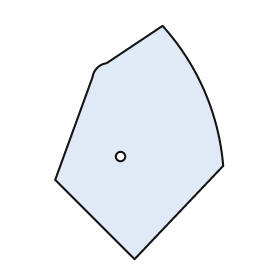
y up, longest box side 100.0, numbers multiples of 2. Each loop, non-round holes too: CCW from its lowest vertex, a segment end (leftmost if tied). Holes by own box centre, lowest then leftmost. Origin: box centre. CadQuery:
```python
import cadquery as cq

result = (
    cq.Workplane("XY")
    .moveTo(-2.0, -50.0)
    .lineTo(36.0, -10.0)
    .threePointArc((28.0, 22.0), (10.0, 50.0))
    .lineTo(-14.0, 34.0)
    .threePointArc((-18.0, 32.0), (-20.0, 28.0))
    .lineTo(-36.0, -16.0)
    .close()
    .moveTo(-8.0, -6.0)
    .circle(2.0)
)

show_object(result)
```